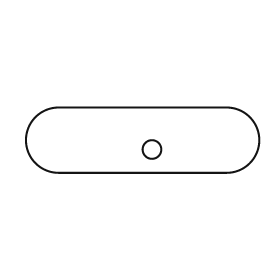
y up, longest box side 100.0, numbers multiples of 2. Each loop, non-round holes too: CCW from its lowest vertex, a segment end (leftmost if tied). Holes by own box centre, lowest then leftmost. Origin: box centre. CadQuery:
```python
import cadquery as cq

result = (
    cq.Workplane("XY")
    .moveTo(-36.0, -14.0)
    .lineTo(36.0, -14.0)
    .threePointArc((50.0, 0.0), (36.0, 14.0))
    .lineTo(-36.0, 14.0)
    .threePointArc((-50.0, 0.0), (-36.0, -14.0))
    .close()
    .moveTo(4.0, -4.0)
    .circle(4.0)
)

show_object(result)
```